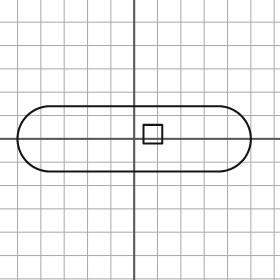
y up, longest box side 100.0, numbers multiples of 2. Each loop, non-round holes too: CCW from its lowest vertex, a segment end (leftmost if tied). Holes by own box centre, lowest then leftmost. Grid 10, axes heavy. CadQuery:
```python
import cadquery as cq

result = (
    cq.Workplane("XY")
    .moveTo(-36.0, -14.0)
    .lineTo(36.0, -14.0)
    .threePointArc((50.0, 0.0), (36.0, 14.0))
    .lineTo(-36.0, 14.0)
    .threePointArc((-50.0, 0.0), (-36.0, -14.0))
    .close()
    .moveTo(4.0, -2.0)
    .lineTo(12.0, -2.0)
    .lineTo(12.0, 6.0)
    .lineTo(4.0, 6.0)
    .close()
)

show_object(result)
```